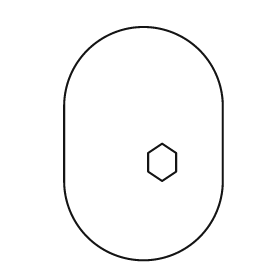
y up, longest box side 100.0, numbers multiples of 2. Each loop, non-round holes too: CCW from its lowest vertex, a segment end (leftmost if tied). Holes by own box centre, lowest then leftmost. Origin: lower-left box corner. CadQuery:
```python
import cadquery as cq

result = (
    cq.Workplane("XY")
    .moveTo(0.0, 34.0)
    .threePointArc((34.0, 0.0), (68.0, 34.0))
    .lineTo(68.0, 66.0)
    .threePointArc((34.0, 100.0), (0.0, 66.0))
    .close()
    .moveTo(42.0, 34.0)
    .lineTo(48.0, 38.0)
    .lineTo(48.0, 46.0)
    .lineTo(42.0, 50.0)
    .lineTo(36.0, 46.0)
    .lineTo(36.0, 38.0)
    .close()
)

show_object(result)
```